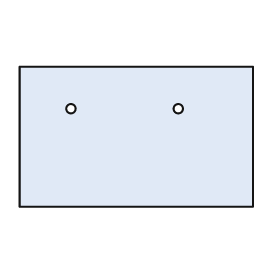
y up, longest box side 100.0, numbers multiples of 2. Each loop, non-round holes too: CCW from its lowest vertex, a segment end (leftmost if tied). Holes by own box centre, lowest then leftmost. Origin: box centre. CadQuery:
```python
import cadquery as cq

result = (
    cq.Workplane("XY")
    .moveTo(-50.0, -30.0)
    .lineTo(50.0, -30.0)
    .lineTo(50.0, 30.0)
    .lineTo(-50.0, 30.0)
    .close()
    .moveTo(-28.0, 12.0)
    .circle(2.0)
    .moveTo(18.0, 12.0)
    .circle(2.0)
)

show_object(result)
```